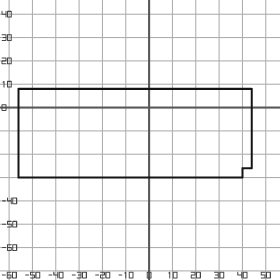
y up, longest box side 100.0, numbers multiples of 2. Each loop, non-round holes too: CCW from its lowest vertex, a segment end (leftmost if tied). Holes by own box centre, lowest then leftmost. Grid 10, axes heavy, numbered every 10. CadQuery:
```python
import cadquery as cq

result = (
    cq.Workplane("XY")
    .moveTo(-56.0, -30.0)
    .lineTo(40.0, -30.0)
    .lineTo(40.0, -26.0)
    .lineTo(44.0, -26.0)
    .lineTo(44.0, 8.0)
    .lineTo(-56.0, 8.0)
    .close()
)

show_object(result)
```